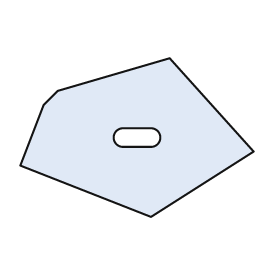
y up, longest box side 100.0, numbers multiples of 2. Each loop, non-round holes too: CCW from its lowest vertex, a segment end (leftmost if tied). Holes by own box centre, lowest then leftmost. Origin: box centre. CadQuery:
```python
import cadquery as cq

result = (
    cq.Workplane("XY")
    .moveTo(6.0, -34.0)
    .lineTo(50.0, -6.0)
    .lineTo(14.0, 34.0)
    .lineTo(-34.0, 20.0)
    .lineTo(-40.0, 14.0)
    .lineTo(-50.0, -12.0)
    .close()
    .moveTo(-6.0, -4.0)
    .lineTo(6.0, -4.0)
    .threePointArc((10.0, 0.0), (6.0, 4.0))
    .lineTo(-6.0, 4.0)
    .threePointArc((-10.0, 0.0), (-6.0, -4.0))
    .close()
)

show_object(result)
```